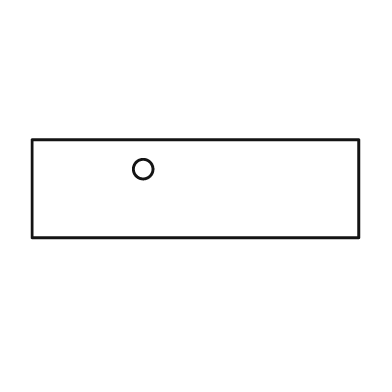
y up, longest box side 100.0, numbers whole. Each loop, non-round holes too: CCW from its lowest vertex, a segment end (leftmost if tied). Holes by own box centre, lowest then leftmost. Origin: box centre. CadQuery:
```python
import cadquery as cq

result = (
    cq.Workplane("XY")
    .moveTo(-50.0, -15.0)
    .lineTo(50.0, -15.0)
    .lineTo(50.0, 15.0)
    .lineTo(-50.0, 15.0)
    .close()
    .moveTo(-16.0, 6.0)
    .circle(3.0)
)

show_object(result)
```